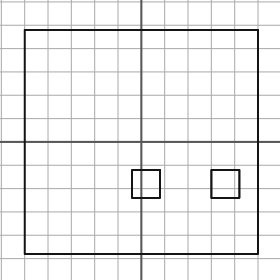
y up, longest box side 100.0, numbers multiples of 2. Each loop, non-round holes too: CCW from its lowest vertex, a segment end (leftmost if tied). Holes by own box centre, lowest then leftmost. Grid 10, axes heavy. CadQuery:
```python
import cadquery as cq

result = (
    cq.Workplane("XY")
    .moveTo(-50.0, -48.0)
    .lineTo(50.0, -48.0)
    .lineTo(50.0, 48.0)
    .lineTo(-50.0, 48.0)
    .close()
    .moveTo(-4.0, -24.0)
    .lineTo(8.0, -24.0)
    .lineTo(8.0, -12.0)
    .lineTo(-4.0, -12.0)
    .close()
    .moveTo(30.0, -24.0)
    .lineTo(42.0, -24.0)
    .lineTo(42.0, -12.0)
    .lineTo(30.0, -12.0)
    .close()
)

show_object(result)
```